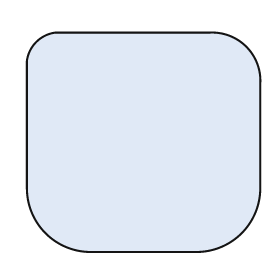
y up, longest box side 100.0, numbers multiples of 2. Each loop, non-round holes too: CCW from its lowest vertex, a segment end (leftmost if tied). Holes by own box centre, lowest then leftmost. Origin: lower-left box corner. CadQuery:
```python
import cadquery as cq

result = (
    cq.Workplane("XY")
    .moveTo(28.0, 0.0)
    .lineTo(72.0, 0.0)
    .threePointArc((92.0, 8.0), (100.0, 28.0))
    .lineTo(100.0, 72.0)
    .threePointArc((94.0, 88.0), (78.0, 94.0))
    .lineTo(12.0, 94.0)
    .threePointArc((4.0, 90.0), (0.0, 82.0))
    .lineTo(0.0, 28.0)
    .threePointArc((8.0, 8.0), (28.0, 0.0))
    .close()
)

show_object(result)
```